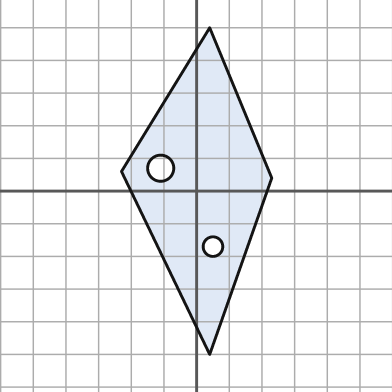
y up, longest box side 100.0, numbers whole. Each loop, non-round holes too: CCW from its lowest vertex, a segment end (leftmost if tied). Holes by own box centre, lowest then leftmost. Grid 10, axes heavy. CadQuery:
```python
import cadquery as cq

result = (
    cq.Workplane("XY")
    .moveTo(4.0, -50.0)
    .lineTo(23.0, 4.0)
    .lineTo(4.0, 50.0)
    .lineTo(-23.0, 6.0)
    .close()
    .moveTo(5.0, -17.0)
    .circle(3.0)
    .moveTo(-11.0, 7.0)
    .circle(4.0)
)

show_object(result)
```